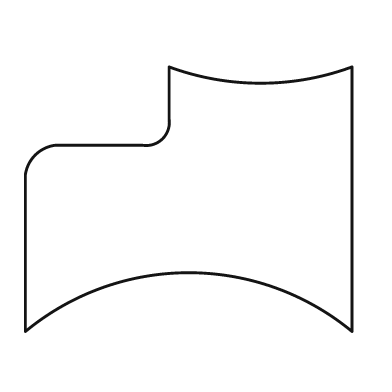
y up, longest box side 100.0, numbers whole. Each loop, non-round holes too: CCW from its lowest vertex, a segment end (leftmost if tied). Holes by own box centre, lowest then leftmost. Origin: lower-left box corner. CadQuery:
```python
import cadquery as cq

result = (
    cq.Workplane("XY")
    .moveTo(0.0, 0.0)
    .threePointArc((50.0, 18.0), (100.0, 0.0))
    .lineTo(100.0, 81.0)
    .threePointArc((72.0, 76.0), (44.0, 81.0))
    .lineTo(44.0, 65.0)
    .threePointArc((42.0, 59.0), (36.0, 57.0))
    .lineTo(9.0, 57.0)
    .threePointArc((3.0, 54.0), (0.0, 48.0))
    .close()
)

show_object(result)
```